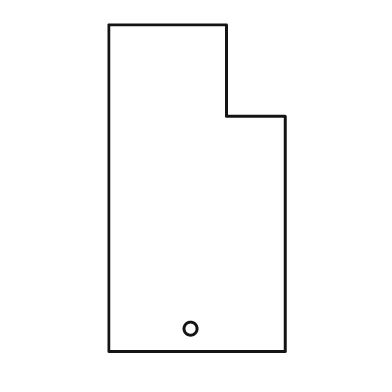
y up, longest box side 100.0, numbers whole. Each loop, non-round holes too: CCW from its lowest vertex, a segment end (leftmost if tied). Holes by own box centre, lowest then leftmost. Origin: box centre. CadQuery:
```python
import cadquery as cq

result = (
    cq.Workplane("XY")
    .moveTo(-27.0, -50.0)
    .lineTo(27.0, -50.0)
    .lineTo(27.0, 22.0)
    .lineTo(9.0, 22.0)
    .lineTo(9.0, 50.0)
    .lineTo(-27.0, 50.0)
    .close()
    .moveTo(-2.0, -43.0)
    .circle(2.0)
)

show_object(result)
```